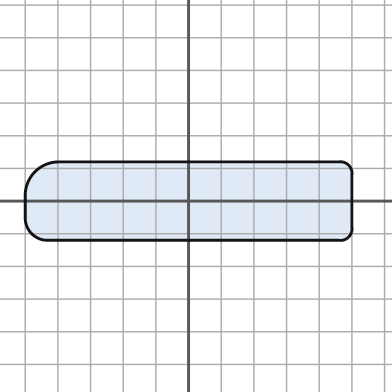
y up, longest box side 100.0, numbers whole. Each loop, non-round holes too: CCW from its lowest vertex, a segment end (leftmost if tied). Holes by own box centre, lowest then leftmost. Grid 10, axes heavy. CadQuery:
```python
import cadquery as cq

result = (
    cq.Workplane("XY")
    .moveTo(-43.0, -12.0)
    .lineTo(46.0, -12.0)
    .threePointArc((49.0, -11.0), (50.0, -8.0))
    .lineTo(50.0, 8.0)
    .threePointArc((49.0, 11.0), (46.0, 12.0))
    .lineTo(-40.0, 12.0)
    .threePointArc((-47.0, 9.0), (-50.0, 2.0))
    .lineTo(-50.0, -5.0)
    .threePointArc((-48.0, -10.0), (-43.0, -12.0))
    .close()
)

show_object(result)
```